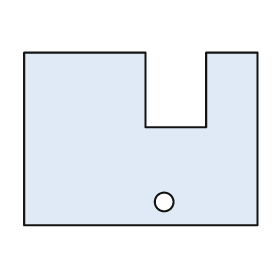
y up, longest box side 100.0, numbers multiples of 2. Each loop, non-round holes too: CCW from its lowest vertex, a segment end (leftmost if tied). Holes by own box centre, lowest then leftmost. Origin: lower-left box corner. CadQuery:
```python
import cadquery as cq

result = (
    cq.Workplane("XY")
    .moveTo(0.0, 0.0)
    .lineTo(100.0, 0.0)
    .lineTo(100.0, 74.0)
    .lineTo(78.0, 74.0)
    .lineTo(78.0, 42.0)
    .lineTo(52.0, 42.0)
    .lineTo(52.0, 74.0)
    .lineTo(0.0, 74.0)
    .close()
    .moveTo(60.0, 10.0)
    .circle(4.0)
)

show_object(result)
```